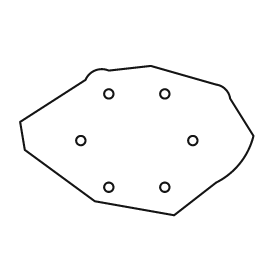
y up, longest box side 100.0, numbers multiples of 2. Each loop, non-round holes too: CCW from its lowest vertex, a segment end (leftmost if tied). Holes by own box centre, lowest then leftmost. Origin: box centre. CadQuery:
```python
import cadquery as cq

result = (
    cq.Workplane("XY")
    .moveTo(16.0, -32.0)
    .lineTo(34.0, -18.0)
    .threePointArc((44.0, -10.0), (50.0, 2.0))
    .lineTo(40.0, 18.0)
    .threePointArc((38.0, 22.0), (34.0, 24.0))
    .lineTo(6.0, 32.0)
    .lineTo(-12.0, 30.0)
    .threePointArc((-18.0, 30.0), (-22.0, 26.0))
    .lineTo(-50.0, 8.0)
    .lineTo(-48.0, -4.0)
    .lineTo(-18.0, -26.0)
    .close()
    .moveTo(-12.0, -20.0)
    .circle(2.0)
    .moveTo(12.0, -20.0)
    .circle(2.0)
    .moveTo(-24.0, 0.0)
    .circle(2.0)
    .moveTo(24.0, 0.0)
    .circle(2.0)
    .moveTo(-12.0, 20.0)
    .circle(2.0)
    .moveTo(12.0, 20.0)
    .circle(2.0)
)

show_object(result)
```